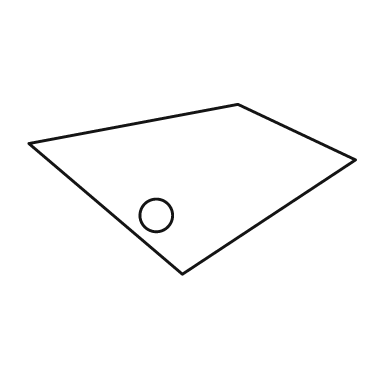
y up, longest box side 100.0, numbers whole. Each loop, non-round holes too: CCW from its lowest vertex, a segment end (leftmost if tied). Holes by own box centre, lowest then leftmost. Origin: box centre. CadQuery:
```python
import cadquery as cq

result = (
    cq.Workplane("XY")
    .moveTo(-3.0, -26.0)
    .lineTo(50.0, 9.0)
    .lineTo(14.0, 26.0)
    .lineTo(-50.0, 14.0)
    .close()
    .moveTo(-11.0, -8.0)
    .circle(5.0)
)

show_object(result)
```